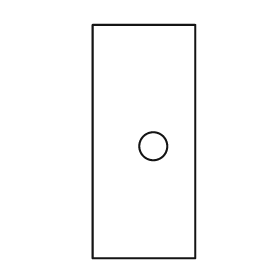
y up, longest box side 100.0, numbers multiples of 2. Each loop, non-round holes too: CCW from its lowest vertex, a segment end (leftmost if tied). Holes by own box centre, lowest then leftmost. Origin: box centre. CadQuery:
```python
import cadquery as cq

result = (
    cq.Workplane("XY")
    .moveTo(-22.0, -50.0)
    .lineTo(22.0, -50.0)
    .lineTo(22.0, 50.0)
    .lineTo(-22.0, 50.0)
    .close()
    .moveTo(4.0, -2.0)
    .circle(6.0)
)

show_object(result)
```